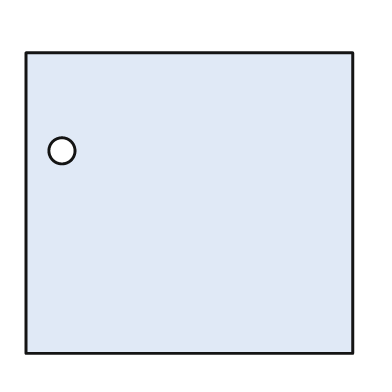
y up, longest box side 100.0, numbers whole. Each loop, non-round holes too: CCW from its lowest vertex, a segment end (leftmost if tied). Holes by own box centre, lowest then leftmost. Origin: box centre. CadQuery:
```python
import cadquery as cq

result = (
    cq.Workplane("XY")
    .moveTo(-50.0, -46.0)
    .lineTo(50.0, -46.0)
    .lineTo(50.0, 46.0)
    .lineTo(-50.0, 46.0)
    .close()
    .moveTo(-39.0, 16.0)
    .circle(4.0)
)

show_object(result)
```